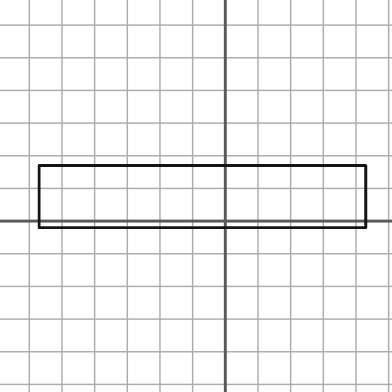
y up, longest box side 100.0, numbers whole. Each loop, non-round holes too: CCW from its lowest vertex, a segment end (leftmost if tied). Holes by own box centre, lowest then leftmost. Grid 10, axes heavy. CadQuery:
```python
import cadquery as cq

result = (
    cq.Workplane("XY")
    .moveTo(-57.0, -2.0)
    .lineTo(43.0, -2.0)
    .lineTo(43.0, 17.0)
    .lineTo(-57.0, 17.0)
    .close()
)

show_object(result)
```